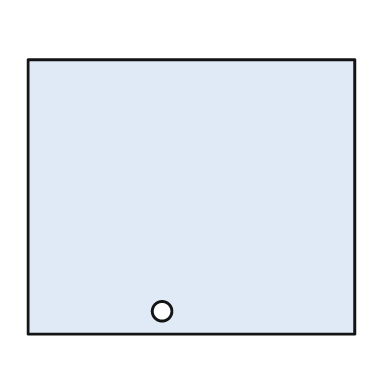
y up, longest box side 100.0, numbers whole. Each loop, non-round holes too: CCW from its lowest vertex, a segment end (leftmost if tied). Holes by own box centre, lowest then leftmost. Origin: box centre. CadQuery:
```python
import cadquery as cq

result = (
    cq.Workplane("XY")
    .moveTo(-50.0, -42.0)
    .lineTo(50.0, -42.0)
    .lineTo(50.0, 42.0)
    .lineTo(-50.0, 42.0)
    .close()
    .moveTo(-9.0, -35.0)
    .circle(3.0)
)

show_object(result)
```